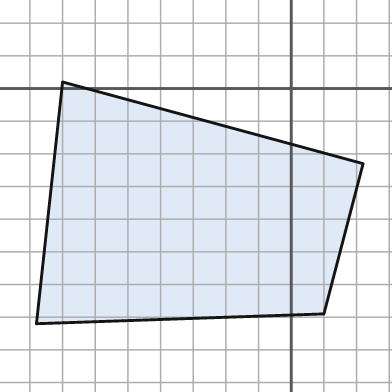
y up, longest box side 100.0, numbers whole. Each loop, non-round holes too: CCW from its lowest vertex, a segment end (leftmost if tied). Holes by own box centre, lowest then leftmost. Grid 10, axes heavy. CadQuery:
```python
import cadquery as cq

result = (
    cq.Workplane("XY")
    .moveTo(-78.0, -72.0)
    .lineTo(10.0, -69.0)
    .lineTo(22.0, -23.0)
    .lineTo(-70.0, 2.0)
    .close()
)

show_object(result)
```